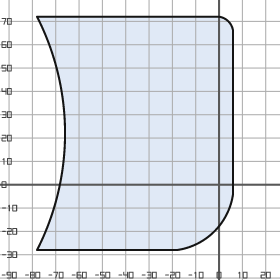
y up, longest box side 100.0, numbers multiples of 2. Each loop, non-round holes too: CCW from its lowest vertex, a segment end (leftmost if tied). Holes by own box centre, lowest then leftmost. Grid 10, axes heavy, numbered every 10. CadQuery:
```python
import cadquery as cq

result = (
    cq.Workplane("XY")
    .moveTo(-78.0, -28.0)
    .lineTo(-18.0, -28.0)
    .threePointArc((-2.0, -20.0), (6.0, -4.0))
    .lineTo(6.0, 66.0)
    .threePointArc((4.0, 70.0), (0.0, 72.0))
    .lineTo(-78.0, 72.0)
    .threePointArc((-66.0, 22.0), (-78.0, -28.0))
    .close()
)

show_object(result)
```